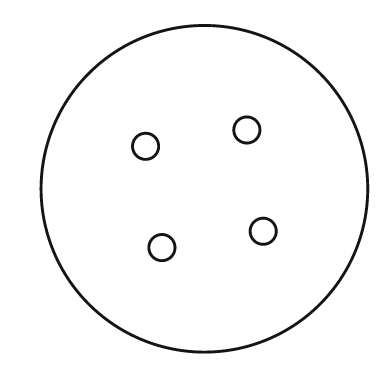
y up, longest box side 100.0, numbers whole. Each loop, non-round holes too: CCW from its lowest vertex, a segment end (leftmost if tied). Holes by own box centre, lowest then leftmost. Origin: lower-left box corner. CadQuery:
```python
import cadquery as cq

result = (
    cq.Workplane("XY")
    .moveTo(50.0, 50.0)
    .circle(50.0)
    .moveTo(37.0, 32.0)
    .circle(4.0)
    .moveTo(68.0, 37.0)
    .circle(4.0)
    .moveTo(32.0, 63.0)
    .circle(4.0)
    .moveTo(63.0, 68.0)
    .circle(4.0)
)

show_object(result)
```